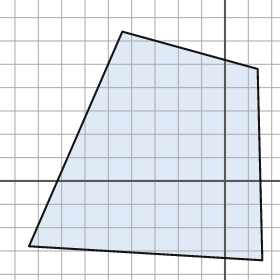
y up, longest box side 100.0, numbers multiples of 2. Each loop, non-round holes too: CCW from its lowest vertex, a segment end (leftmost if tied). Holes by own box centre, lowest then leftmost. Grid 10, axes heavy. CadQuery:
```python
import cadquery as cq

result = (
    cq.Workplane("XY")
    .moveTo(16.0, -34.0)
    .lineTo(14.0, 48.0)
    .lineTo(-44.0, 64.0)
    .lineTo(-84.0, -28.0)
    .close()
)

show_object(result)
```